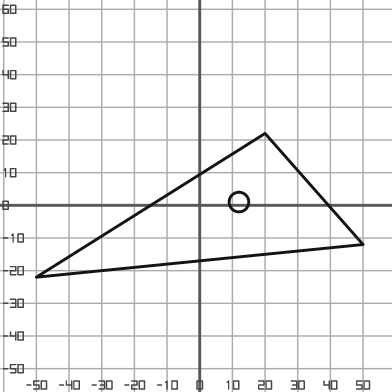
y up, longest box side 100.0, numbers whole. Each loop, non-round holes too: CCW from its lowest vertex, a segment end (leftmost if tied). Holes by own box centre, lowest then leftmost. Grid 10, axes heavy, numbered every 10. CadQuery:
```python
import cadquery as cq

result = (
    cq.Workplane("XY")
    .moveTo(-50.0, -22.0)
    .lineTo(50.0, -12.0)
    .lineTo(20.0, 22.0)
    .close()
    .moveTo(12.0, 1.0)
    .circle(3.0)
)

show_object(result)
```